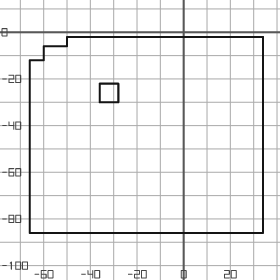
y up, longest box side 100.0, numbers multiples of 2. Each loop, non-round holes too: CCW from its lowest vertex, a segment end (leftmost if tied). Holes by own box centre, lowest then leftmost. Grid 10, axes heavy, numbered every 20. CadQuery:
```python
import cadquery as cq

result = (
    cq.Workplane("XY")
    .moveTo(-66.0, -86.0)
    .lineTo(34.0, -86.0)
    .lineTo(34.0, -2.0)
    .lineTo(-50.0, -2.0)
    .lineTo(-50.0, -6.0)
    .lineTo(-60.0, -6.0)
    .lineTo(-60.0, -12.0)
    .lineTo(-66.0, -12.0)
    .close()
    .moveTo(-36.0, -30.0)
    .lineTo(-28.0, -30.0)
    .lineTo(-28.0, -22.0)
    .lineTo(-36.0, -22.0)
    .close()
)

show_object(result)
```